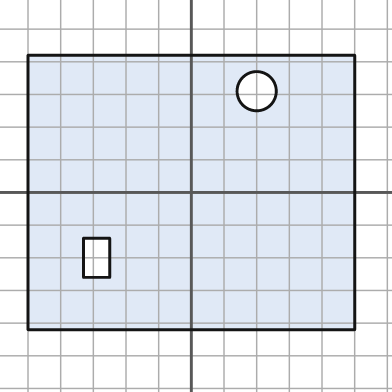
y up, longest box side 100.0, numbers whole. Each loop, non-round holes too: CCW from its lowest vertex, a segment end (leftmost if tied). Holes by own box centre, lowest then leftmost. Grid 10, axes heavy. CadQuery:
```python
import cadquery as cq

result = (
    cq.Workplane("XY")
    .moveTo(-50.0, -42.0)
    .lineTo(50.0, -42.0)
    .lineTo(50.0, 42.0)
    .lineTo(-50.0, 42.0)
    .close()
    .moveTo(-33.0, -26.0)
    .lineTo(-25.0, -26.0)
    .lineTo(-25.0, -14.0)
    .lineTo(-33.0, -14.0)
    .close()
    .moveTo(20.0, 31.0)
    .circle(6.0)
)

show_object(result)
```